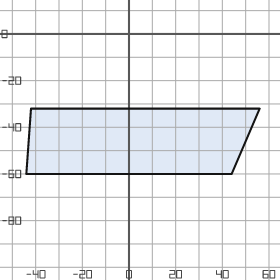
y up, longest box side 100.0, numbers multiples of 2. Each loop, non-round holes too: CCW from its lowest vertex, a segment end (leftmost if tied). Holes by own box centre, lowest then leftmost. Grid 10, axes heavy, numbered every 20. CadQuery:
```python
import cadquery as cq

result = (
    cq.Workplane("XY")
    .moveTo(-44.0, -60.0)
    .lineTo(44.0, -60.0)
    .lineTo(56.0, -32.0)
    .lineTo(-42.0, -32.0)
    .close()
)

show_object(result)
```